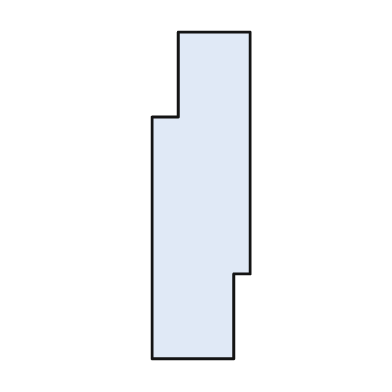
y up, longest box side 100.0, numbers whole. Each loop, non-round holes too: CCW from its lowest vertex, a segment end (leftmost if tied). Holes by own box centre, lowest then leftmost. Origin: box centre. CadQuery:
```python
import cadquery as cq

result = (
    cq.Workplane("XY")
    .moveTo(-15.0, -50.0)
    .lineTo(10.0, -50.0)
    .lineTo(10.0, -24.0)
    .lineTo(15.0, -24.0)
    .lineTo(15.0, 50.0)
    .lineTo(-7.0, 50.0)
    .lineTo(-7.0, 24.0)
    .lineTo(-15.0, 24.0)
    .close()
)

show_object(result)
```